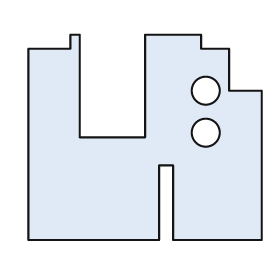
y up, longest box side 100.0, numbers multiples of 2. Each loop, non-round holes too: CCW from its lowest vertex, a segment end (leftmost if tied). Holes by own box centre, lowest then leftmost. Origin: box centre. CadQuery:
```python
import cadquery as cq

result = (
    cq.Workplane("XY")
    .moveTo(-50.0, -44.0)
    .lineTo(6.0, -44.0)
    .lineTo(6.0, -12.0)
    .lineTo(12.0, -12.0)
    .lineTo(12.0, -44.0)
    .lineTo(50.0, -44.0)
    .lineTo(50.0, 20.0)
    .lineTo(36.0, 20.0)
    .lineTo(36.0, 38.0)
    .lineTo(24.0, 38.0)
    .lineTo(24.0, 44.0)
    .lineTo(0.0, 44.0)
    .lineTo(0.0, 0.0)
    .lineTo(-28.0, 0.0)
    .lineTo(-28.0, 44.0)
    .lineTo(-32.0, 44.0)
    .lineTo(-32.0, 38.0)
    .lineTo(-50.0, 38.0)
    .close()
    .moveTo(26.0, 2.0)
    .circle(6.0)
    .moveTo(26.0, 20.0)
    .circle(6.0)
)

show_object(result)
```